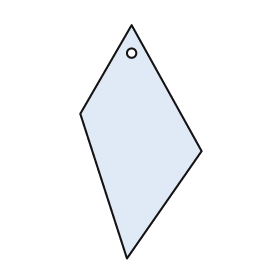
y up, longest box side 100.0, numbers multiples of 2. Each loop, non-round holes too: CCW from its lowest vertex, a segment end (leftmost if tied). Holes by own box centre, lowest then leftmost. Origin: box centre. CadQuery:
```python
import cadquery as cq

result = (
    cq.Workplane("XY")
    .moveTo(-6.0, -50.0)
    .lineTo(26.0, -4.0)
    .lineTo(-4.0, 50.0)
    .lineTo(-26.0, 12.0)
    .close()
    .moveTo(-4.0, 38.0)
    .circle(2.0)
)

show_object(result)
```